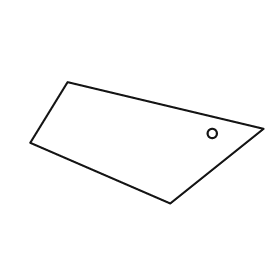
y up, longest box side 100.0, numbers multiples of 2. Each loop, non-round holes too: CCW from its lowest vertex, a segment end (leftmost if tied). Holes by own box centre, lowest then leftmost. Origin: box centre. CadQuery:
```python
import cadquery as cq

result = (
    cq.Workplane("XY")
    .moveTo(10.0, -26.0)
    .lineTo(50.0, 6.0)
    .lineTo(-34.0, 26.0)
    .lineTo(-50.0, 0.0)
    .close()
    .moveTo(28.0, 4.0)
    .circle(2.0)
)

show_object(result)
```